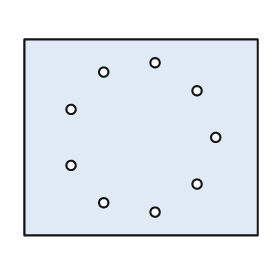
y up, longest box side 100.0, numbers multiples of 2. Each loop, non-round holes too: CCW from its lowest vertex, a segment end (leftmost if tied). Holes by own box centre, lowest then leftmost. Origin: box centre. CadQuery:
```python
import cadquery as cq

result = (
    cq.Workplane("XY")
    .moveTo(-50.0, -42.0)
    .lineTo(50.0, -42.0)
    .lineTo(50.0, 42.0)
    .lineTo(-50.0, 42.0)
    .close()
    .moveTo(6.0, -32.0)
    .circle(2.0)
    .moveTo(-16.0, -28.0)
    .circle(2.0)
    .moveTo(24.0, -20.0)
    .circle(2.0)
    .moveTo(-30.0, -12.0)
    .circle(2.0)
    .moveTo(32.0, 0.0)
    .circle(2.0)
    .moveTo(-30.0, 12.0)
    .circle(2.0)
    .moveTo(24.0, 20.0)
    .circle(2.0)
    .moveTo(-16.0, 28.0)
    .circle(2.0)
    .moveTo(6.0, 32.0)
    .circle(2.0)
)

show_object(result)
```